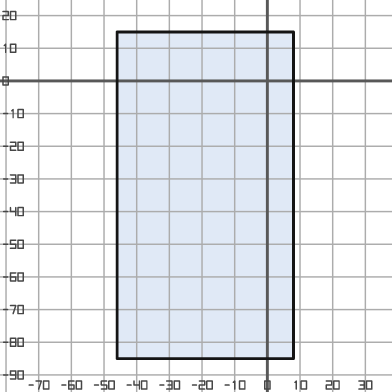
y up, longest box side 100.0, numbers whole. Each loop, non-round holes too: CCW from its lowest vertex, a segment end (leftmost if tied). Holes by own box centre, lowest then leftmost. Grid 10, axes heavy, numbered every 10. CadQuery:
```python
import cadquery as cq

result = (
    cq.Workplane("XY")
    .moveTo(-46.0, -85.0)
    .lineTo(8.0, -85.0)
    .lineTo(8.0, 15.0)
    .lineTo(-46.0, 15.0)
    .close()
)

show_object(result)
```